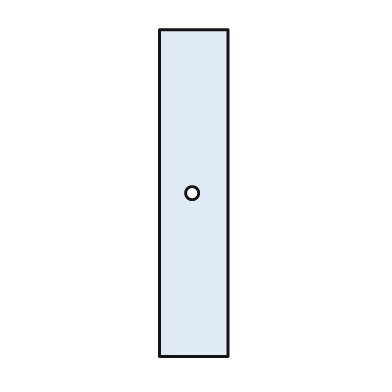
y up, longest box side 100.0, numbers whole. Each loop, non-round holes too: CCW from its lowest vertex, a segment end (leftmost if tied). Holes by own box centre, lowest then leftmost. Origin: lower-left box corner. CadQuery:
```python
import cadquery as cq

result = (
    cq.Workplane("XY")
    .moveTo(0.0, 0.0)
    .lineTo(21.0, 0.0)
    .lineTo(21.0, 100.0)
    .lineTo(0.0, 100.0)
    .close()
    .moveTo(10.0, 50.0)
    .circle(2.0)
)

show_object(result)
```